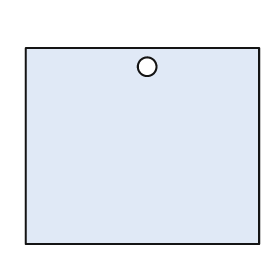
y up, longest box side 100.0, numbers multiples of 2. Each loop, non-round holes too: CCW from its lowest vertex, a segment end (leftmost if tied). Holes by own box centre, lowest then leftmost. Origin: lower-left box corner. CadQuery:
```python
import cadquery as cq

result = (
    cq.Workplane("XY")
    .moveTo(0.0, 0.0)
    .lineTo(100.0, 0.0)
    .lineTo(100.0, 84.0)
    .lineTo(0.0, 84.0)
    .close()
    .moveTo(52.0, 76.0)
    .circle(4.0)
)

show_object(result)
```